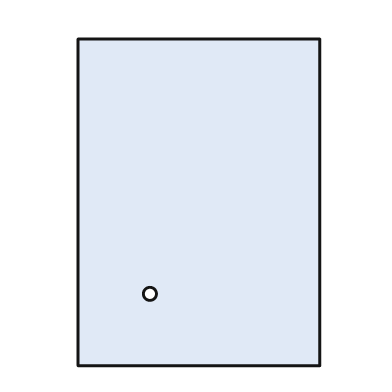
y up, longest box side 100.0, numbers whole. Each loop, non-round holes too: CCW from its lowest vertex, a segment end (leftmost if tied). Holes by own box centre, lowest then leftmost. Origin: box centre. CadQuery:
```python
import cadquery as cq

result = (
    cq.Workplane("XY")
    .moveTo(-37.0, -50.0)
    .lineTo(37.0, -50.0)
    .lineTo(37.0, 50.0)
    .lineTo(-37.0, 50.0)
    .close()
    .moveTo(-15.0, -28.0)
    .circle(2.0)
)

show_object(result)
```